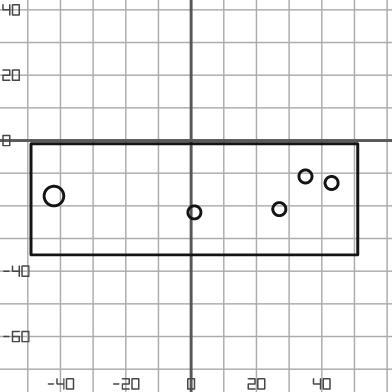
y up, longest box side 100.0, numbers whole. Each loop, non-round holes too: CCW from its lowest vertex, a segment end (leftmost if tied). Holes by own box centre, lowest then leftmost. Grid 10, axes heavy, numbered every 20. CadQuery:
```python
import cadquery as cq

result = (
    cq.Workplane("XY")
    .moveTo(-49.0, -35.0)
    .lineTo(51.0, -35.0)
    .lineTo(51.0, -1.0)
    .lineTo(-49.0, -1.0)
    .close()
    .moveTo(1.0, -22.0)
    .circle(2.0)
    .moveTo(27.0, -21.0)
    .circle(2.0)
    .moveTo(-42.0, -17.0)
    .circle(3.0)
    .moveTo(43.0, -13.0)
    .circle(2.0)
    .moveTo(35.0, -11.0)
    .circle(2.0)
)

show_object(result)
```